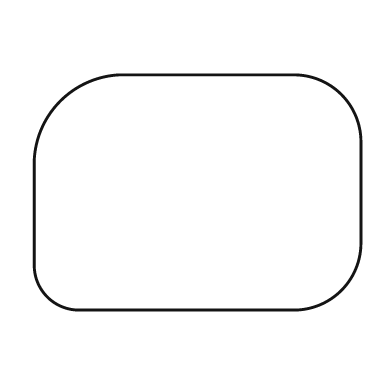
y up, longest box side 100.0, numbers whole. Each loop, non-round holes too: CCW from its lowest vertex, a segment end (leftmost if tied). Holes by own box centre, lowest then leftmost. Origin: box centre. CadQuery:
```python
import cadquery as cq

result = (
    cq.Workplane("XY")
    .moveTo(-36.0, -36.0)
    .lineTo(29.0, -36.0)
    .threePointArc((44.0, -30.0), (50.0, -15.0))
    .lineTo(50.0, 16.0)
    .threePointArc((44.0, 30.0), (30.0, 36.0))
    .lineTo(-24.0, 36.0)
    .threePointArc((-42.0, 28.0), (-50.0, 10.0))
    .lineTo(-50.0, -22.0)
    .threePointArc((-46.0, -32.0), (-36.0, -36.0))
    .close()
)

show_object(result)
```